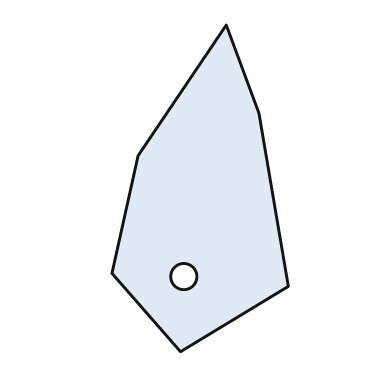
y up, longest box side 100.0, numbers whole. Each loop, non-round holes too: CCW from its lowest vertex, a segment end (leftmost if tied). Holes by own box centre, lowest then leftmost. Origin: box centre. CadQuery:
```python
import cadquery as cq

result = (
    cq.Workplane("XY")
    .moveTo(-6.0, -50.0)
    .lineTo(27.0, -30.0)
    .lineTo(18.0, 23.0)
    .lineTo(8.0, 50.0)
    .lineTo(-19.0, 10.0)
    .lineTo(-27.0, -26.0)
    .close()
    .moveTo(-5.0, -27.0)
    .circle(4.0)
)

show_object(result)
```